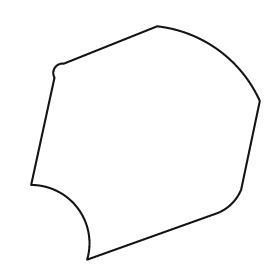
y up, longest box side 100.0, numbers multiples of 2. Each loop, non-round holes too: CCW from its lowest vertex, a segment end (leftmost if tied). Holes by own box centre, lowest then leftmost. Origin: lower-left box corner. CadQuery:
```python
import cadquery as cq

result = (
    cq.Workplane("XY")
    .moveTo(24.0, 0.0)
    .lineTo(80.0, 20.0)
    .threePointArc((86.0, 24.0), (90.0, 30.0))
    .lineTo(98.0, 68.0)
    .threePointArc((80.0, 90.0), (54.0, 100.0))
    .lineTo(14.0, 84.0)
    .threePointArc((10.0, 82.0), (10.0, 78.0))
    .lineTo(0.0, 32.0)
    .threePointArc((20.0, 22.0), (24.0, 0.0))
    .close()
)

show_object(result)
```